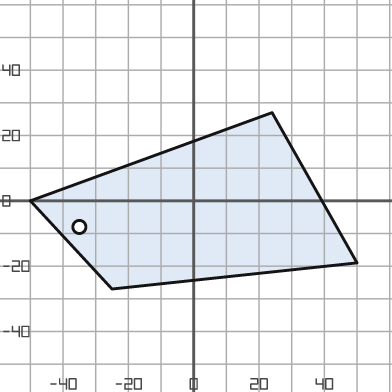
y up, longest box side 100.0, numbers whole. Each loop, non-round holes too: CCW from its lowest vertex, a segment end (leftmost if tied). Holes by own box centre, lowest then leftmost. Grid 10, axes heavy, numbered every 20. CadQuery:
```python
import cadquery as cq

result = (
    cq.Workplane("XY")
    .moveTo(-25.0, -27.0)
    .lineTo(50.0, -19.0)
    .lineTo(24.0, 27.0)
    .lineTo(-50.0, 0.0)
    .close()
    .moveTo(-35.0, -8.0)
    .circle(2.0)
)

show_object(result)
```